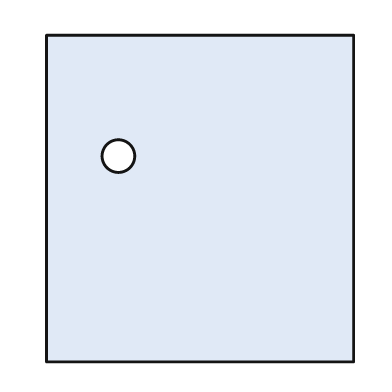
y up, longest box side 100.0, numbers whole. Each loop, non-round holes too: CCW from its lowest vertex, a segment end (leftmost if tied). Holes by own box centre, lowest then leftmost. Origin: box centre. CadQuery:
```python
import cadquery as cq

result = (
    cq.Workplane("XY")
    .moveTo(-47.0, -50.0)
    .lineTo(47.0, -50.0)
    .lineTo(47.0, 50.0)
    .lineTo(-47.0, 50.0)
    .close()
    .moveTo(-25.0, 13.0)
    .circle(5.0)
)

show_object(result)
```